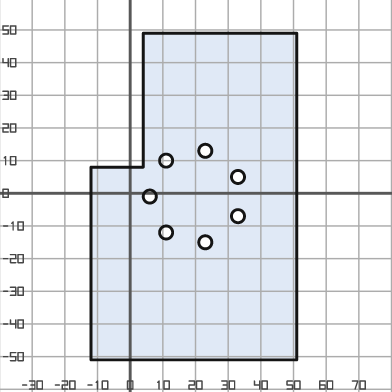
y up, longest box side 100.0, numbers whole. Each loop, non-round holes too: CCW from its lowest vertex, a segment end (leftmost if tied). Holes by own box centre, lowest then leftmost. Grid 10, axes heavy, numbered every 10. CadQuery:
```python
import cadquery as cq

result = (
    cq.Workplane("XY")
    .moveTo(-12.0, -51.0)
    .lineTo(51.0, -51.0)
    .lineTo(51.0, 49.0)
    .lineTo(4.0, 49.0)
    .lineTo(4.0, 8.0)
    .lineTo(-12.0, 8.0)
    .close()
    .moveTo(23.0, -15.0)
    .circle(2.0)
    .moveTo(11.0, -12.0)
    .circle(2.0)
    .moveTo(33.0, -7.0)
    .circle(2.0)
    .moveTo(6.0, -1.0)
    .circle(2.0)
    .moveTo(33.0, 5.0)
    .circle(2.0)
    .moveTo(11.0, 10.0)
    .circle(2.0)
    .moveTo(23.0, 13.0)
    .circle(2.0)
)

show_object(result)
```